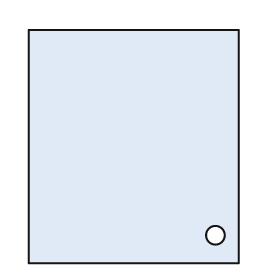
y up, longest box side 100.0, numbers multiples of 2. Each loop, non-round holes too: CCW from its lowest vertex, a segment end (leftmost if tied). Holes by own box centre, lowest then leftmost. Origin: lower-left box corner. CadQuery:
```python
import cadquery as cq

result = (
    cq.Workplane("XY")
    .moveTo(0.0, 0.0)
    .lineTo(90.0, 0.0)
    .lineTo(90.0, 100.0)
    .lineTo(0.0, 100.0)
    .close()
    .moveTo(80.0, 12.0)
    .circle(4.0)
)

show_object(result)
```